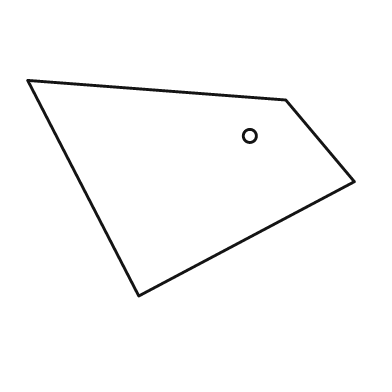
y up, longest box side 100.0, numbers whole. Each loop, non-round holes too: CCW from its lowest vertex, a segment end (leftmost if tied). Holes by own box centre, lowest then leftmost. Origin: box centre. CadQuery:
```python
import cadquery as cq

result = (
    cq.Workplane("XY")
    .moveTo(-16.0, -33.0)
    .lineTo(50.0, 2.0)
    .lineTo(29.0, 27.0)
    .lineTo(-50.0, 33.0)
    .close()
    .moveTo(18.0, 16.0)
    .circle(2.0)
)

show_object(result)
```